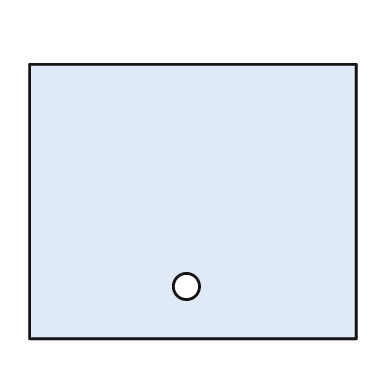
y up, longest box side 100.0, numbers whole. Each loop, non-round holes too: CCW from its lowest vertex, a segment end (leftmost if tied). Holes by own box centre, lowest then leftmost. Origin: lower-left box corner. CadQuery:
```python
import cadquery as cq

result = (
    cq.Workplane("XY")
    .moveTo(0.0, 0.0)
    .lineTo(100.0, 0.0)
    .lineTo(100.0, 84.0)
    .lineTo(0.0, 84.0)
    .close()
    .moveTo(48.0, 16.0)
    .circle(4.0)
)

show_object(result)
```